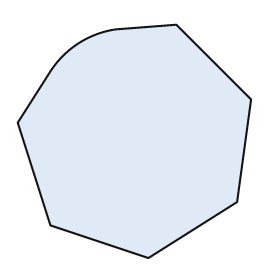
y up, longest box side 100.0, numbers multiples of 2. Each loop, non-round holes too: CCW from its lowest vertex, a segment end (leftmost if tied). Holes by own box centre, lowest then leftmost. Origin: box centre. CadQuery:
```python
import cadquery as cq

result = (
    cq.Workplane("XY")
    .moveTo(6.0, -50.0)
    .lineTo(44.0, -26.0)
    .lineTo(50.0, 18.0)
    .lineTo(18.0, 50.0)
    .lineTo(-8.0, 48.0)
    .threePointArc((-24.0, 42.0), (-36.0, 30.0))
    .lineTo(-50.0, 8.0)
    .lineTo(-36.0, -36.0)
    .close()
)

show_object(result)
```